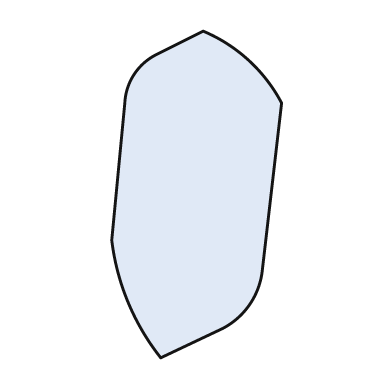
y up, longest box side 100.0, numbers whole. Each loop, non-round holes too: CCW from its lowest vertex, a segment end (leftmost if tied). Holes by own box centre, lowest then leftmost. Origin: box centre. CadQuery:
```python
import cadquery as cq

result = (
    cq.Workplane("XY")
    .moveTo(-11.0, -50.0)
    .lineTo(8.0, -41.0)
    .threePointArc((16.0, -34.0), (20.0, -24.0))
    .lineTo(26.0, 28.0)
    .threePointArc((16.0, 41.0), (2.0, 50.0))
    .lineTo(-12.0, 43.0)
    .threePointArc((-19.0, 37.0), (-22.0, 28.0))
    .lineTo(-26.0, -14.0)
    .threePointArc((-21.0, -33.0), (-11.0, -50.0))
    .close()
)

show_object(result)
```